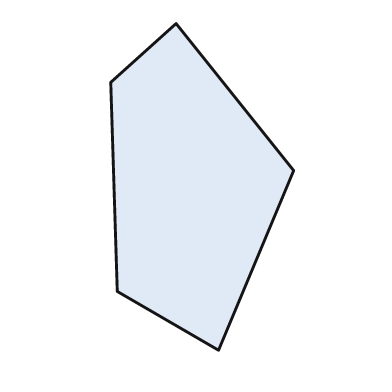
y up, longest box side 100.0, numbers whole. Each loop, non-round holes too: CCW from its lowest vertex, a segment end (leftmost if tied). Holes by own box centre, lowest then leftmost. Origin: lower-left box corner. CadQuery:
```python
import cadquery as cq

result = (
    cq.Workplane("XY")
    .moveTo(33.0, 0.0)
    .lineTo(56.0, 55.0)
    .lineTo(20.0, 100.0)
    .lineTo(0.0, 82.0)
    .lineTo(2.0, 18.0)
    .close()
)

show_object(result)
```